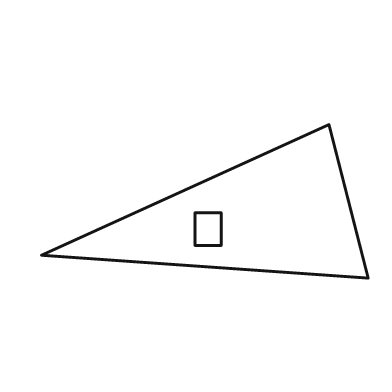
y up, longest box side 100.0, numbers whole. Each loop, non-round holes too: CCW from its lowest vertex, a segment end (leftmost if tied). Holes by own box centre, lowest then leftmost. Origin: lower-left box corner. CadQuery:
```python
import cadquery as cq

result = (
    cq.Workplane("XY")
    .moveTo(100.0, 0.0)
    .lineTo(88.0, 47.0)
    .lineTo(0.0, 7.0)
    .close()
    .moveTo(47.0, 10.0)
    .lineTo(55.0, 10.0)
    .lineTo(55.0, 20.0)
    .lineTo(47.0, 20.0)
    .close()
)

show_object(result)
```